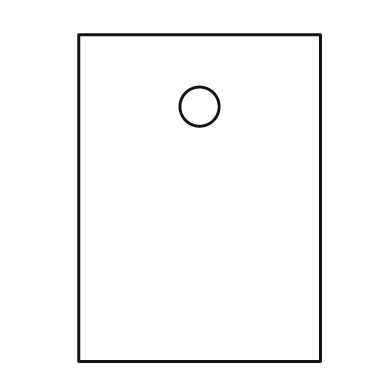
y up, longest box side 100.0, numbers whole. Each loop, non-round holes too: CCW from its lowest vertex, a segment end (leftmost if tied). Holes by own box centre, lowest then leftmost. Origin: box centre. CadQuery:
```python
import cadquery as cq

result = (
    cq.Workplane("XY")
    .moveTo(-37.0, -50.0)
    .lineTo(37.0, -50.0)
    .lineTo(37.0, 50.0)
    .lineTo(-37.0, 50.0)
    .close()
    .moveTo(0.0, 28.0)
    .circle(6.0)
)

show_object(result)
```